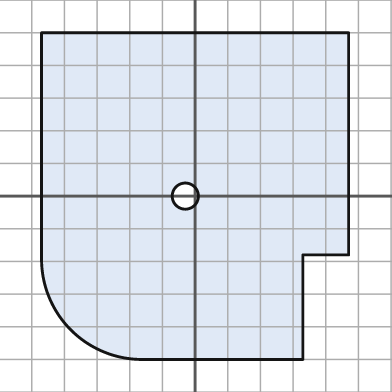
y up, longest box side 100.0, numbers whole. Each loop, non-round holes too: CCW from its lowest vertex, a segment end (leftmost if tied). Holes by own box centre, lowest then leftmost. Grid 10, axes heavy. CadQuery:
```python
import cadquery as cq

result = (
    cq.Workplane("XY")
    .moveTo(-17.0, -50.0)
    .lineTo(33.0, -50.0)
    .lineTo(33.0, -18.0)
    .lineTo(47.0, -18.0)
    .lineTo(47.0, 50.0)
    .lineTo(-47.0, 50.0)
    .lineTo(-47.0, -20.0)
    .threePointArc((-38.0, -41.0), (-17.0, -50.0))
    .close()
    .moveTo(-3.0, 0.0)
    .circle(4.0)
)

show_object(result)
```